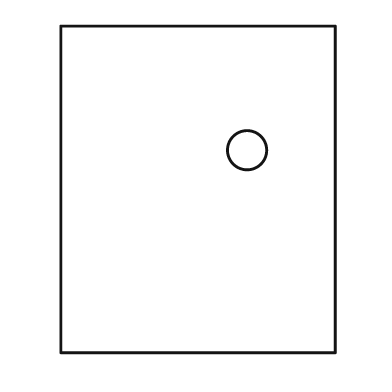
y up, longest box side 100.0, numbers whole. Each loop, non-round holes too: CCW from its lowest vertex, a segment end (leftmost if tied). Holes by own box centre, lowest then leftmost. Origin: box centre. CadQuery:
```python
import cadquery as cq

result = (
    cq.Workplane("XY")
    .moveTo(-42.0, -50.0)
    .lineTo(42.0, -50.0)
    .lineTo(42.0, 50.0)
    .lineTo(-42.0, 50.0)
    .close()
    .moveTo(15.0, 12.0)
    .circle(6.0)
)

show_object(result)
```